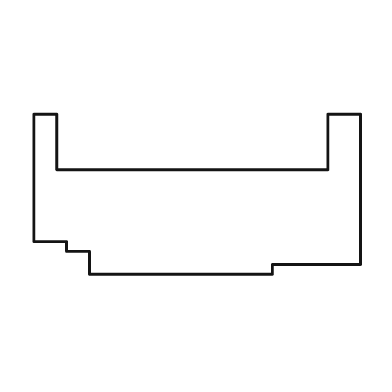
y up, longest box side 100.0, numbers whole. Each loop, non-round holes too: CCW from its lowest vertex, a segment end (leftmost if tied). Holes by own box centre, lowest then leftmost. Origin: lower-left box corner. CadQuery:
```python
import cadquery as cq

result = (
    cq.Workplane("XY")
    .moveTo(17.0, 0.0)
    .lineTo(73.0, 0.0)
    .lineTo(73.0, 3.0)
    .lineTo(100.0, 3.0)
    .lineTo(100.0, 49.0)
    .lineTo(90.0, 49.0)
    .lineTo(90.0, 32.0)
    .lineTo(7.0, 32.0)
    .lineTo(7.0, 49.0)
    .lineTo(0.0, 49.0)
    .lineTo(0.0, 10.0)
    .lineTo(10.0, 10.0)
    .lineTo(10.0, 7.0)
    .lineTo(17.0, 7.0)
    .close()
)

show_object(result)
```